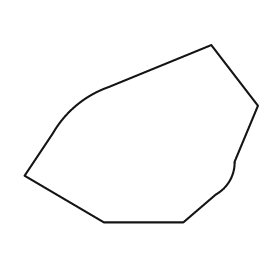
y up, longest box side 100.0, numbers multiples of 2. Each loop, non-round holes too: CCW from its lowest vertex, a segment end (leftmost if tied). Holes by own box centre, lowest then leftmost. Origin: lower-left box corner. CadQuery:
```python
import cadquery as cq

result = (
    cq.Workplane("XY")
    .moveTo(34.0, 0.0)
    .lineTo(68.0, 0.0)
    .lineTo(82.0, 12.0)
    .threePointArc((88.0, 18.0), (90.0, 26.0))
    .lineTo(100.0, 50.0)
    .lineTo(80.0, 76.0)
    .lineTo(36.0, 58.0)
    .threePointArc((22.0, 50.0), (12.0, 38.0))
    .lineTo(0.0, 20.0)
    .close()
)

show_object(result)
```